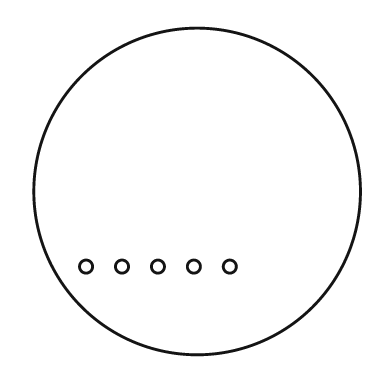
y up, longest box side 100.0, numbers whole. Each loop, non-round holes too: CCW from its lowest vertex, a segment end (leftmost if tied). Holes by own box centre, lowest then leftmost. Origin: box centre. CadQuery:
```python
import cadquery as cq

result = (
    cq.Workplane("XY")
    .moveTo(0.0, 0.0)
    .circle(50.0)
    .moveTo(-34.0, -23.0)
    .circle(2.0)
    .moveTo(-23.0, -23.0)
    .circle(2.0)
    .moveTo(-12.0, -23.0)
    .circle(2.0)
    .moveTo(-1.0, -23.0)
    .circle(2.0)
    .moveTo(10.0, -23.0)
    .circle(2.0)
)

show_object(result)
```